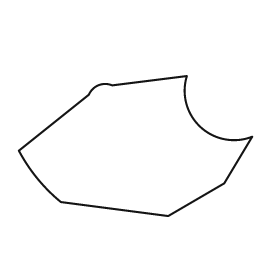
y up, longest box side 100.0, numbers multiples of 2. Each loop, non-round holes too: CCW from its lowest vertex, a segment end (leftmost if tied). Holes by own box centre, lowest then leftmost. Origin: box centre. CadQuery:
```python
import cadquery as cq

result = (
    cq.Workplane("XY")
    .moveTo(14.0, -30.0)
    .lineTo(38.0, -16.0)
    .lineTo(50.0, 4.0)
    .threePointArc((28.0, 8.0), (22.0, 30.0))
    .lineTo(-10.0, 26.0)
    .threePointArc((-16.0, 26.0), (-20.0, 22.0))
    .lineTo(-50.0, -2.0)
    .threePointArc((-42.0, -14.0), (-32.0, -24.0))
    .close()
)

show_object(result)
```